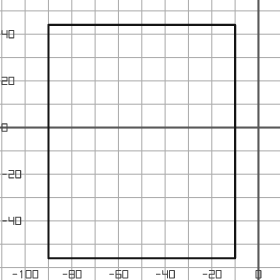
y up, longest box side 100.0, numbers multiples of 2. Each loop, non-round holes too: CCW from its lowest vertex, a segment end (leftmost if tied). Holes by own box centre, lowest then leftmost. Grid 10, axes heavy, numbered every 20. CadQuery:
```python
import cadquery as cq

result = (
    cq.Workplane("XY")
    .moveTo(-90.0, -56.0)
    .lineTo(-10.0, -56.0)
    .lineTo(-10.0, 44.0)
    .lineTo(-90.0, 44.0)
    .close()
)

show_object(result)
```